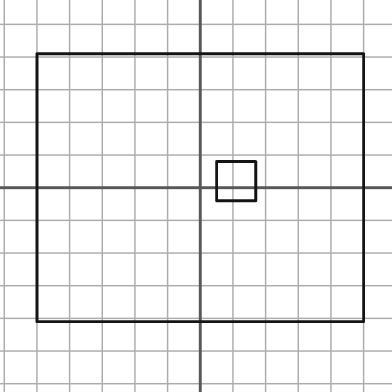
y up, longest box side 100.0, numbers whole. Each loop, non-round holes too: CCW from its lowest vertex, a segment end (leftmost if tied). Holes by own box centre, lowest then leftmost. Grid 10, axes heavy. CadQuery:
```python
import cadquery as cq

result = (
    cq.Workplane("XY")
    .moveTo(-50.0, -41.0)
    .lineTo(50.0, -41.0)
    .lineTo(50.0, 41.0)
    .lineTo(-50.0, 41.0)
    .close()
    .moveTo(5.0, -4.0)
    .lineTo(17.0, -4.0)
    .lineTo(17.0, 8.0)
    .lineTo(5.0, 8.0)
    .close()
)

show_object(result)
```